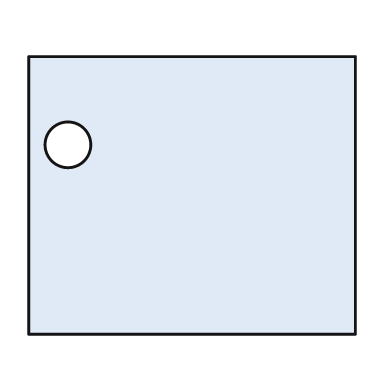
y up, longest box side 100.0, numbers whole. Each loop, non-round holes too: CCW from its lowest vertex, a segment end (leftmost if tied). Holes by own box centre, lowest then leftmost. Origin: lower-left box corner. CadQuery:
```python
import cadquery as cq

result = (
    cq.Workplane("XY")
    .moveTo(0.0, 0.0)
    .lineTo(100.0, 0.0)
    .lineTo(100.0, 85.0)
    .lineTo(0.0, 85.0)
    .close()
    .moveTo(12.0, 58.0)
    .circle(7.0)
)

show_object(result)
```